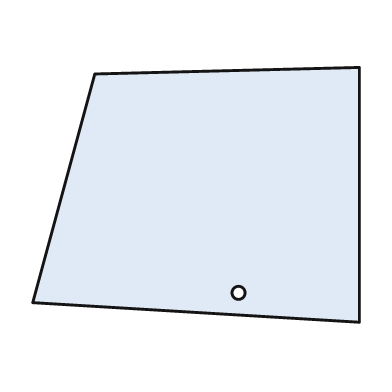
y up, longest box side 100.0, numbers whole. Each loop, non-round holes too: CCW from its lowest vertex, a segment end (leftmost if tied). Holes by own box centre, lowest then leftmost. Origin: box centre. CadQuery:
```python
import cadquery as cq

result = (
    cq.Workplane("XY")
    .moveTo(50.0, -39.0)
    .lineTo(50.0, 39.0)
    .lineTo(-31.0, 37.0)
    .lineTo(-50.0, -33.0)
    .close()
    .moveTo(13.0, -30.0)
    .circle(2.0)
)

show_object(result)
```